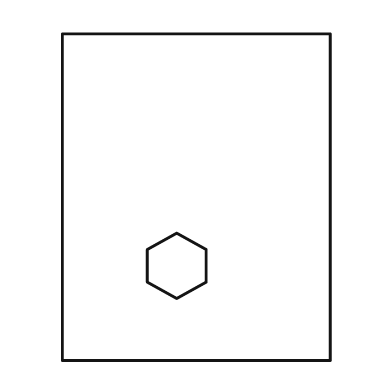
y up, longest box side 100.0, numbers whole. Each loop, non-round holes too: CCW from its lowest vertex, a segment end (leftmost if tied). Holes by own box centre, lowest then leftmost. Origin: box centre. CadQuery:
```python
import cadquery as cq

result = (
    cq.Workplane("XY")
    .moveTo(-41.0, -50.0)
    .lineTo(41.0, -50.0)
    .lineTo(41.0, 50.0)
    .lineTo(-41.0, 50.0)
    .close()
    .moveTo(-6.0, -31.0)
    .lineTo(3.0, -26.0)
    .lineTo(3.0, -16.0)
    .lineTo(-6.0, -11.0)
    .lineTo(-15.0, -16.0)
    .lineTo(-15.0, -26.0)
    .close()
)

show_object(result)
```